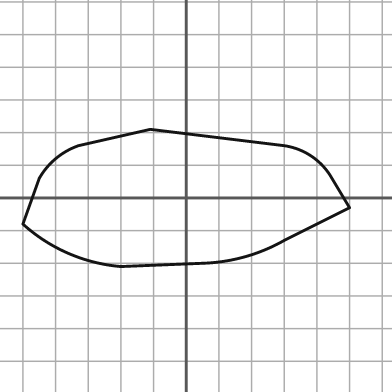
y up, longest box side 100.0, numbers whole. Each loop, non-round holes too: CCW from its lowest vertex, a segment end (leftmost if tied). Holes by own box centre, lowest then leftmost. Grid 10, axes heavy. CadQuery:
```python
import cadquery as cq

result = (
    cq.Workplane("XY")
    .moveTo(-20.0, -21.0)
    .lineTo(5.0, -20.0)
    .threePointArc((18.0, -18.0), (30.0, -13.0))
    .lineTo(50.0, -3.0)
    .lineTo(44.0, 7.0)
    .threePointArc((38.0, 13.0), (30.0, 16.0))
    .lineTo(-11.0, 21.0)
    .lineTo(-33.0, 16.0)
    .threePointArc((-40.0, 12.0), (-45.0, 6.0))
    .lineTo(-50.0, -8.0)
    .threePointArc((-36.0, -17.0), (-20.0, -21.0))
    .close()
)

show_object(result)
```